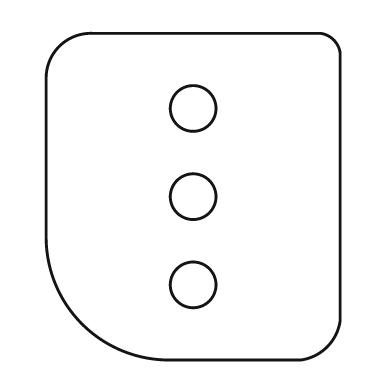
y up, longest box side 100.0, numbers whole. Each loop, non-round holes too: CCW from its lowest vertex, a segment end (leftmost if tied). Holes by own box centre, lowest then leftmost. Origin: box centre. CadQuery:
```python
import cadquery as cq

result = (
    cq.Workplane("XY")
    .moveTo(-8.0, -50.0)
    .lineTo(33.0, -50.0)
    .threePointArc((41.0, -46.0), (45.0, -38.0))
    .lineTo(45.0, 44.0)
    .threePointArc((43.0, 48.0), (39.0, 50.0))
    .lineTo(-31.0, 50.0)
    .threePointArc((-41.0, 46.0), (-45.0, 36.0))
    .lineTo(-45.0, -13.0)
    .threePointArc((-34.0, -39.0), (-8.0, -50.0))
    .close()
    .moveTo(0.0, -27.0)
    .circle(7.0)
    .moveTo(0.0, 0.0)
    .circle(7.0)
    .moveTo(0.0, 27.0)
    .circle(7.0)
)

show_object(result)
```